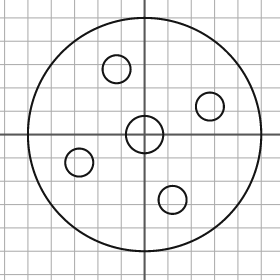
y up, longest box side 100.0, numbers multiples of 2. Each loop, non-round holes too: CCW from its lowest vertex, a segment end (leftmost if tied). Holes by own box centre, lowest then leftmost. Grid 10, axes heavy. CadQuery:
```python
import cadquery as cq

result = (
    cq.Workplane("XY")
    .moveTo(0.0, 0.0)
    .circle(50.0)
    .moveTo(12.0, -28.0)
    .circle(6.0)
    .moveTo(-28.0, -12.0)
    .circle(6.0)
    .moveTo(0.0, 0.0)
    .circle(8.0)
    .moveTo(28.0, 12.0)
    .circle(6.0)
    .moveTo(-12.0, 28.0)
    .circle(6.0)
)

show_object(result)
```